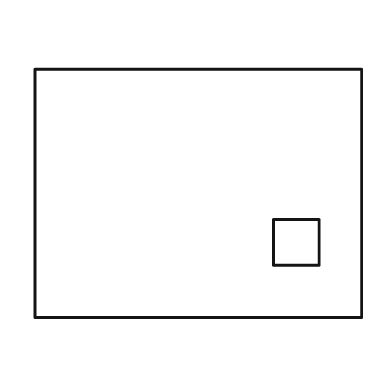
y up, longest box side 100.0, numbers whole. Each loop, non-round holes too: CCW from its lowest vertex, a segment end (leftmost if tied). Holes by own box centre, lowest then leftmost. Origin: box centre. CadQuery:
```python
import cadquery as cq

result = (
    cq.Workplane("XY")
    .moveTo(-50.0, -38.0)
    .lineTo(50.0, -38.0)
    .lineTo(50.0, 38.0)
    .lineTo(-50.0, 38.0)
    .close()
    .moveTo(23.0, -22.0)
    .lineTo(37.0, -22.0)
    .lineTo(37.0, -8.0)
    .lineTo(23.0, -8.0)
    .close()
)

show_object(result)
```